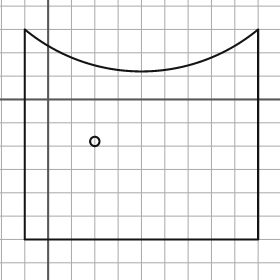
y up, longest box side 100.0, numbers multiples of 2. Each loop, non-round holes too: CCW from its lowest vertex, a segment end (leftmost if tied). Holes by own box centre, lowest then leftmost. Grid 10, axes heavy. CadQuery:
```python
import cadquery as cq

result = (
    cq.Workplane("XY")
    .moveTo(-10.0, -60.0)
    .lineTo(90.0, -60.0)
    .lineTo(90.0, 30.0)
    .threePointArc((40.0, 12.0), (-10.0, 30.0))
    .close()
    .moveTo(20.0, -18.0)
    .circle(2.0)
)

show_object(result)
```